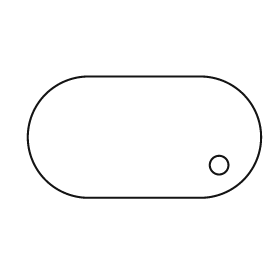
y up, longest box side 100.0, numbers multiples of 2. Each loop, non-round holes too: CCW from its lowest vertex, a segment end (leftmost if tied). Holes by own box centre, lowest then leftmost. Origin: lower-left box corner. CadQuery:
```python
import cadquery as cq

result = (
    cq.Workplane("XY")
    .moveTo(26.0, 0.0)
    .lineTo(74.0, 0.0)
    .threePointArc((100.0, 26.0), (74.0, 52.0))
    .lineTo(26.0, 52.0)
    .threePointArc((0.0, 26.0), (26.0, 0.0))
    .close()
    .moveTo(82.0, 14.0)
    .circle(4.0)
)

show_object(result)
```